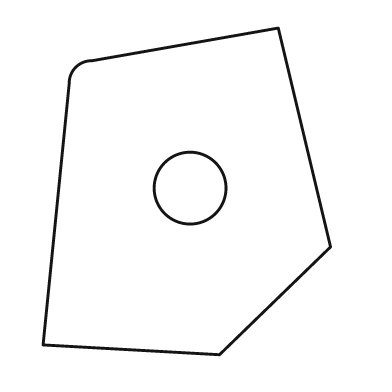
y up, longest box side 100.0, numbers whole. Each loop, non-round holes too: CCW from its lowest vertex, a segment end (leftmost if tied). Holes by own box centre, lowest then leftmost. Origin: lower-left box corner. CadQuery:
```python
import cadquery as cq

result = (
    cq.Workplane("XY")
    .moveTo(54.0, 0.0)
    .lineTo(88.0, 33.0)
    .lineTo(72.0, 100.0)
    .lineTo(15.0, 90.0)
    .threePointArc((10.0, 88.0), (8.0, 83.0))
    .lineTo(0.0, 3.0)
    .close()
    .moveTo(45.0, 51.0)
    .circle(11.0)
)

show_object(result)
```